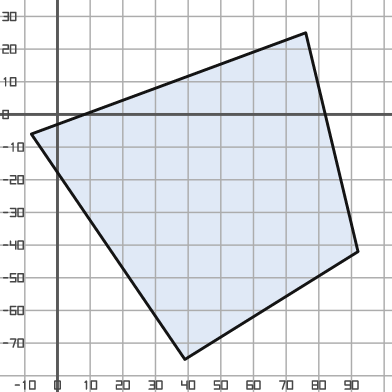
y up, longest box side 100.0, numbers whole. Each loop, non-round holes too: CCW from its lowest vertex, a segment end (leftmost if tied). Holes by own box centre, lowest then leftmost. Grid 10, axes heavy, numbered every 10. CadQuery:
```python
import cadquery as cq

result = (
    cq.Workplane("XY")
    .moveTo(39.0, -75.0)
    .lineTo(92.0, -42.0)
    .lineTo(76.0, 25.0)
    .lineTo(-8.0, -6.0)
    .close()
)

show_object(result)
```